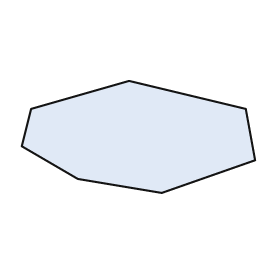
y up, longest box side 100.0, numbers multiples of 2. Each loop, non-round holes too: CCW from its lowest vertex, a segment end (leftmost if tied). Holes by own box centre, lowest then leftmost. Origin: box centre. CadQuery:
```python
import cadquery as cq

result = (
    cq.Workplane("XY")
    .moveTo(10.0, -24.0)
    .lineTo(50.0, -10.0)
    .lineTo(46.0, 12.0)
    .lineTo(-4.0, 24.0)
    .lineTo(-46.0, 12.0)
    .lineTo(-50.0, -4.0)
    .lineTo(-26.0, -18.0)
    .close()
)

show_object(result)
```